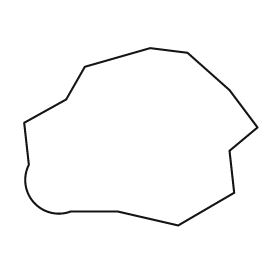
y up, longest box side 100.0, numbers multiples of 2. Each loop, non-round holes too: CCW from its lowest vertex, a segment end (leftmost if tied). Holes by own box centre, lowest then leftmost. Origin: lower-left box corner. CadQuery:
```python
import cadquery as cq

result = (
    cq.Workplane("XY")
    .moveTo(66.0, 0.0)
    .lineTo(90.0, 14.0)
    .lineTo(88.0, 32.0)
    .lineTo(100.0, 42.0)
    .lineTo(88.0, 58.0)
    .lineTo(70.0, 74.0)
    .lineTo(54.0, 76.0)
    .lineTo(26.0, 68.0)
    .lineTo(18.0, 54.0)
    .lineTo(0.0, 44.0)
    .lineTo(2.0, 26.0)
    .threePointArc((4.0, 10.0), (20.0, 6.0))
    .lineTo(40.0, 6.0)
    .close()
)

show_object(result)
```